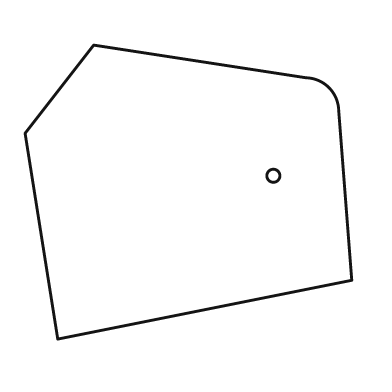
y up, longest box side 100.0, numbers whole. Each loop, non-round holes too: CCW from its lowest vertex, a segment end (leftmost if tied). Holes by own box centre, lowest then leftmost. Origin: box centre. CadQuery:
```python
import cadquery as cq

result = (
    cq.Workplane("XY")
    .moveTo(-40.0, -45.0)
    .lineTo(50.0, -27.0)
    .lineTo(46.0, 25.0)
    .threePointArc((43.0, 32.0), (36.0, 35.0))
    .lineTo(-29.0, 45.0)
    .lineTo(-50.0, 18.0)
    .close()
    .moveTo(26.0, 5.0)
    .circle(2.0)
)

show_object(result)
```